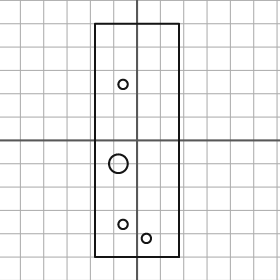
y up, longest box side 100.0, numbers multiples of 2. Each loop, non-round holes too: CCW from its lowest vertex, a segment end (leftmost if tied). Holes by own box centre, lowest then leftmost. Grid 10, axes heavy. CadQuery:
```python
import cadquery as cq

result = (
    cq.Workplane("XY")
    .moveTo(-18.0, -50.0)
    .lineTo(18.0, -50.0)
    .lineTo(18.0, 50.0)
    .lineTo(-18.0, 50.0)
    .close()
    .moveTo(4.0, -42.0)
    .circle(2.0)
    .moveTo(-6.0, -36.0)
    .circle(2.0)
    .moveTo(-8.0, -10.0)
    .circle(4.0)
    .moveTo(-6.0, 24.0)
    .circle(2.0)
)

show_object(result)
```